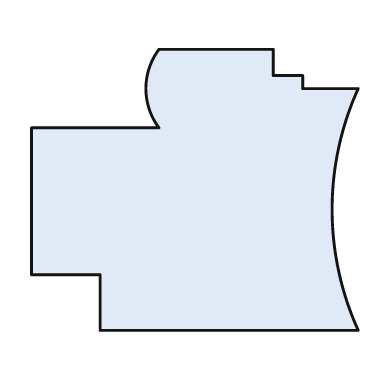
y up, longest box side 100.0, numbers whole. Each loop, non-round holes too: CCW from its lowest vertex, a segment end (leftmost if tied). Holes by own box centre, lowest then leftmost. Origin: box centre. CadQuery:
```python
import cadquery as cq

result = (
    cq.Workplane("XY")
    .moveTo(-29.0, -43.0)
    .lineTo(50.0, -43.0)
    .threePointArc((42.0, -6.0), (50.0, 31.0))
    .lineTo(33.0, 31.0)
    .lineTo(33.0, 35.0)
    .lineTo(24.0, 35.0)
    .lineTo(24.0, 43.0)
    .lineTo(-11.0, 43.0)
    .threePointArc((-15.0, 31.0), (-11.0, 19.0))
    .lineTo(-50.0, 19.0)
    .lineTo(-50.0, -26.0)
    .lineTo(-29.0, -26.0)
    .close()
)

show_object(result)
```